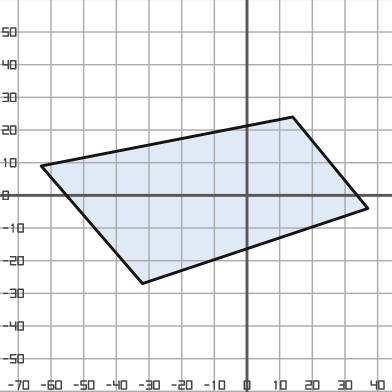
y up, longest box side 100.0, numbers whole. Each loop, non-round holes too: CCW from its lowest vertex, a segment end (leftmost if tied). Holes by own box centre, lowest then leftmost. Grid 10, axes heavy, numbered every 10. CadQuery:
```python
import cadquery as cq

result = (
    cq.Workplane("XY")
    .moveTo(-32.0, -27.0)
    .lineTo(37.0, -4.0)
    .lineTo(14.0, 24.0)
    .lineTo(-63.0, 9.0)
    .close()
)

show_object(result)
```